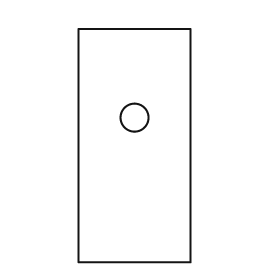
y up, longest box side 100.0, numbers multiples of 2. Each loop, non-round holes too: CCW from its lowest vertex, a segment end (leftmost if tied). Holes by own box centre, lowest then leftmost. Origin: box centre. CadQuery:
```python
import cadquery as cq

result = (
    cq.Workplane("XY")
    .moveTo(-24.0, -50.0)
    .lineTo(24.0, -50.0)
    .lineTo(24.0, 50.0)
    .lineTo(-24.0, 50.0)
    .close()
    .moveTo(0.0, 12.0)
    .circle(6.0)
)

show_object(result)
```